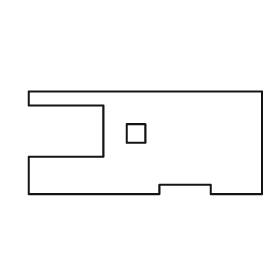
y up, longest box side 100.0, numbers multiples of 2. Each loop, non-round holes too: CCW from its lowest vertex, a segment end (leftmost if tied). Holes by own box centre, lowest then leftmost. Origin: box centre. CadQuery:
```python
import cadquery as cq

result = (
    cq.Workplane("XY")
    .moveTo(-50.0, -22.0)
    .lineTo(6.0, -22.0)
    .lineTo(6.0, -18.0)
    .lineTo(28.0, -18.0)
    .lineTo(28.0, -22.0)
    .lineTo(50.0, -22.0)
    .lineTo(50.0, 22.0)
    .lineTo(-50.0, 22.0)
    .lineTo(-50.0, 16.0)
    .lineTo(-18.0, 16.0)
    .lineTo(-18.0, -6.0)
    .lineTo(-50.0, -6.0)
    .close()
    .moveTo(-8.0, 0.0)
    .lineTo(0.0, 0.0)
    .lineTo(0.0, 8.0)
    .lineTo(-8.0, 8.0)
    .close()
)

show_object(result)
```